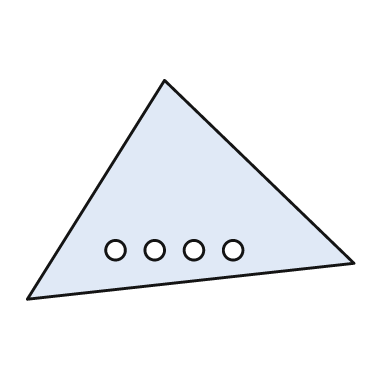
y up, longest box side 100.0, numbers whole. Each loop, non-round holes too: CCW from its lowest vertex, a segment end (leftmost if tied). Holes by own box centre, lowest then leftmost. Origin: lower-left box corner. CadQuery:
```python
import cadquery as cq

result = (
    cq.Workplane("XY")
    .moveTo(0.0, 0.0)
    .lineTo(100.0, 11.0)
    .lineTo(42.0, 67.0)
    .close()
    .moveTo(27.0, 15.0)
    .circle(3.0)
    .moveTo(39.0, 15.0)
    .circle(3.0)
    .moveTo(51.0, 15.0)
    .circle(3.0)
    .moveTo(63.0, 15.0)
    .circle(3.0)
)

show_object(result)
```